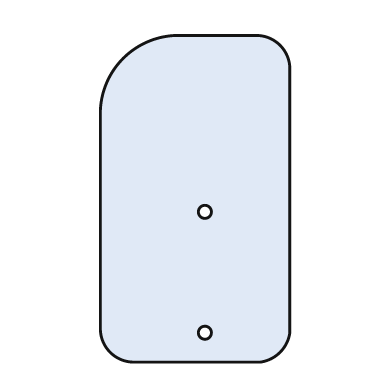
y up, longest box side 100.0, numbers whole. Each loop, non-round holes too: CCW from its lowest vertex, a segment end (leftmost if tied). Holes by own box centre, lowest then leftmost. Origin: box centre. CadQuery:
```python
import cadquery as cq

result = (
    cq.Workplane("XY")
    .moveTo(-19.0, -50.0)
    .lineTo(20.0, -50.0)
    .threePointArc((26.0, -47.0), (29.0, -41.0))
    .lineTo(29.0, 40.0)
    .threePointArc((26.0, 47.0), (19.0, 50.0))
    .lineTo(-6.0, 50.0)
    .threePointArc((-22.0, 43.0), (-29.0, 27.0))
    .lineTo(-29.0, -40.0)
    .threePointArc((-26.0, -47.0), (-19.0, -50.0))
    .close()
    .moveTo(3.0, -41.0)
    .circle(2.0)
    .moveTo(3.0, -4.0)
    .circle(2.0)
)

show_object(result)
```